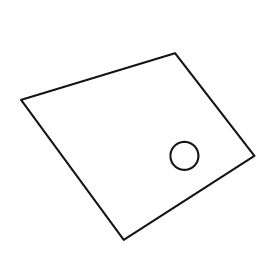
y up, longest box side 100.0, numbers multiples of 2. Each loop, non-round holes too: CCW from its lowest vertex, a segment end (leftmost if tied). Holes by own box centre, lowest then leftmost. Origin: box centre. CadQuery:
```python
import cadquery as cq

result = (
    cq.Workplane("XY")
    .moveTo(-6.0, -40.0)
    .lineTo(50.0, -4.0)
    .lineTo(16.0, 40.0)
    .lineTo(-50.0, 20.0)
    .close()
    .moveTo(20.0, -4.0)
    .circle(6.0)
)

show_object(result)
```